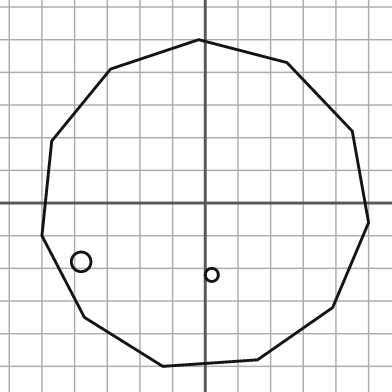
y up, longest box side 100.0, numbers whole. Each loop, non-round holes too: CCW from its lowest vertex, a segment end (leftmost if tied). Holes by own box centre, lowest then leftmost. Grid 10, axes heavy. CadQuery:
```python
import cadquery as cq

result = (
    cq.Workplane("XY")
    .moveTo(-13.0, -50.0)
    .lineTo(16.0, -48.0)
    .lineTo(39.0, -32.0)
    .lineTo(50.0, -6.0)
    .lineTo(45.0, 22.0)
    .lineTo(25.0, 43.0)
    .lineTo(-2.0, 50.0)
    .lineTo(-29.0, 41.0)
    .lineTo(-47.0, 19.0)
    .lineTo(-50.0, -10.0)
    .lineTo(-37.0, -35.0)
    .close()
    .moveTo(2.0, -22.0)
    .circle(2.0)
    .moveTo(-38.0, -18.0)
    .circle(3.0)
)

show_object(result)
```